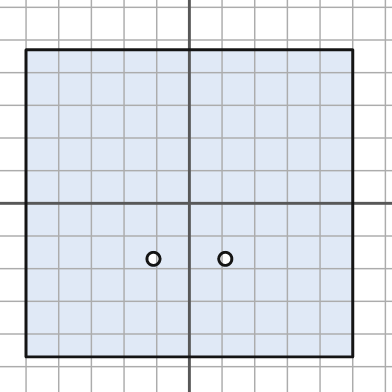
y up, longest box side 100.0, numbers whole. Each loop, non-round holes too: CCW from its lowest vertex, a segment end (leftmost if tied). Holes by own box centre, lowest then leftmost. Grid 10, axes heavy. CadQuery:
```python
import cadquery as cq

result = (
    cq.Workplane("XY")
    .moveTo(-50.0, -47.0)
    .lineTo(50.0, -47.0)
    .lineTo(50.0, 47.0)
    .lineTo(-50.0, 47.0)
    .close()
    .moveTo(-11.0, -17.0)
    .circle(2.0)
    .moveTo(11.0, -17.0)
    .circle(2.0)
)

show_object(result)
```